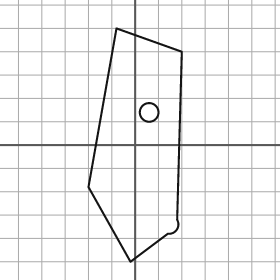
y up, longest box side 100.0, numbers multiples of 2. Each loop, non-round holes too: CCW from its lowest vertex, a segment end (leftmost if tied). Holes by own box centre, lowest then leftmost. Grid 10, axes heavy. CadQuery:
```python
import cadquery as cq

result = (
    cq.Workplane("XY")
    .moveTo(-2.0, -50.0)
    .lineTo(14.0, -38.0)
    .threePointArc((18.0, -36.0), (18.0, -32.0))
    .lineTo(20.0, 40.0)
    .lineTo(-8.0, 50.0)
    .lineTo(-20.0, -18.0)
    .close()
    .moveTo(6.0, 14.0)
    .circle(4.0)
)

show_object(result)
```